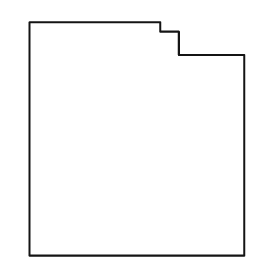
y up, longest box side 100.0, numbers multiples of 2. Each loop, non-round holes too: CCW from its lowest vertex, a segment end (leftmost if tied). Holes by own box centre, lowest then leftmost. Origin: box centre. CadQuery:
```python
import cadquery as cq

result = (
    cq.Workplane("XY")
    .moveTo(-46.0, -50.0)
    .lineTo(46.0, -50.0)
    .lineTo(46.0, 36.0)
    .lineTo(18.0, 36.0)
    .lineTo(18.0, 46.0)
    .lineTo(10.0, 46.0)
    .lineTo(10.0, 50.0)
    .lineTo(-46.0, 50.0)
    .close()
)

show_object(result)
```